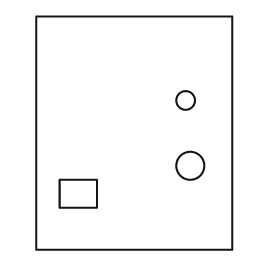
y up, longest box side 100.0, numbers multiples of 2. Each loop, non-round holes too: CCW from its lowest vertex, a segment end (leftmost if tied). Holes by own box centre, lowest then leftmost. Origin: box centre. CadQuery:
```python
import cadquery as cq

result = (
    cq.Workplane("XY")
    .moveTo(-42.0, -50.0)
    .lineTo(42.0, -50.0)
    .lineTo(42.0, 50.0)
    .lineTo(-42.0, 50.0)
    .close()
    .moveTo(-32.0, -32.0)
    .lineTo(-16.0, -32.0)
    .lineTo(-16.0, -20.0)
    .lineTo(-32.0, -20.0)
    .close()
    .moveTo(24.0, -14.0)
    .circle(6.0)
    .moveTo(22.0, 14.0)
    .circle(4.0)
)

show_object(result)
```